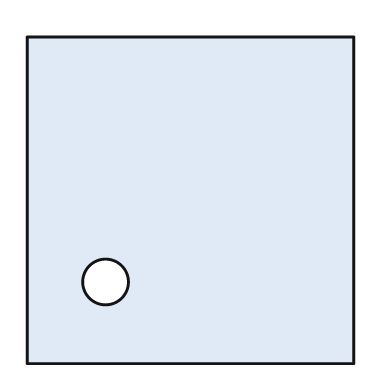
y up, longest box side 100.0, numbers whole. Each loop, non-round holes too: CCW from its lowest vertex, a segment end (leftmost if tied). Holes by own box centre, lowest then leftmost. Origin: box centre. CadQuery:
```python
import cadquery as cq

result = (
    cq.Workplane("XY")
    .moveTo(-50.0, -50.0)
    .lineTo(50.0, -50.0)
    .lineTo(50.0, 50.0)
    .lineTo(-50.0, 50.0)
    .close()
    .moveTo(-26.0, -25.0)
    .circle(7.0)
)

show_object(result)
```